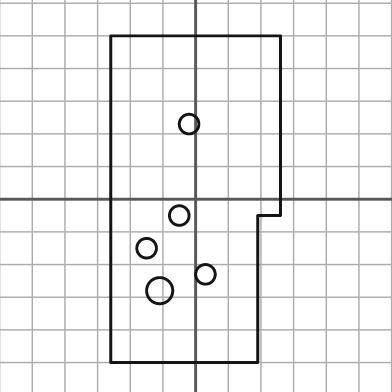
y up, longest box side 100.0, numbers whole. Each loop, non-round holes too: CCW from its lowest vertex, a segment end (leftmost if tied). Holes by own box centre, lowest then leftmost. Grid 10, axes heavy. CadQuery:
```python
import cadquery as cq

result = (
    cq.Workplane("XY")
    .moveTo(-26.0, -50.0)
    .lineTo(19.0, -50.0)
    .lineTo(19.0, -5.0)
    .lineTo(26.0, -5.0)
    .lineTo(26.0, 50.0)
    .lineTo(-26.0, 50.0)
    .close()
    .moveTo(-11.0, -28.0)
    .circle(4.0)
    .moveTo(3.0, -23.0)
    .circle(3.0)
    .moveTo(-15.0, -15.0)
    .circle(3.0)
    .moveTo(-5.0, -5.0)
    .circle(3.0)
    .moveTo(-2.0, 23.0)
    .circle(3.0)
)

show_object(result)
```